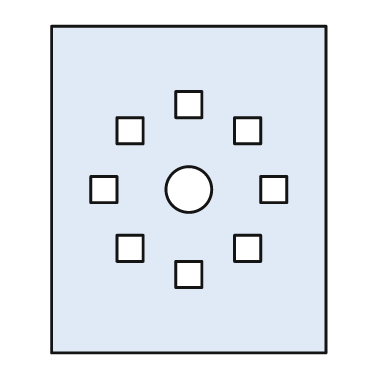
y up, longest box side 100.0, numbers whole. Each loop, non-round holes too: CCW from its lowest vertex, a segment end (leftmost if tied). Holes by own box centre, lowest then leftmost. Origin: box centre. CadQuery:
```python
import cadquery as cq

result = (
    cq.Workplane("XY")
    .moveTo(-42.0, -50.0)
    .lineTo(42.0, -50.0)
    .lineTo(42.0, 50.0)
    .lineTo(-42.0, 50.0)
    .close()
    .moveTo(-4.0, -30.0)
    .lineTo(4.0, -30.0)
    .lineTo(4.0, -22.0)
    .lineTo(-4.0, -22.0)
    .close()
    .moveTo(-22.0, -22.0)
    .lineTo(-14.0, -22.0)
    .lineTo(-14.0, -14.0)
    .lineTo(-22.0, -14.0)
    .close()
    .moveTo(14.0, -22.0)
    .lineTo(22.0, -22.0)
    .lineTo(22.0, -14.0)
    .lineTo(14.0, -14.0)
    .close()
    .moveTo(-30.0, -4.0)
    .lineTo(-22.0, -4.0)
    .lineTo(-22.0, 4.0)
    .lineTo(-30.0, 4.0)
    .close()
    .moveTo(0.0, 0.0)
    .circle(7.0)
    .moveTo(22.0, -4.0)
    .lineTo(30.0, -4.0)
    .lineTo(30.0, 4.0)
    .lineTo(22.0, 4.0)
    .close()
    .moveTo(-22.0, 14.0)
    .lineTo(-14.0, 14.0)
    .lineTo(-14.0, 22.0)
    .lineTo(-22.0, 22.0)
    .close()
    .moveTo(14.0, 14.0)
    .lineTo(22.0, 14.0)
    .lineTo(22.0, 22.0)
    .lineTo(14.0, 22.0)
    .close()
    .moveTo(-4.0, 22.0)
    .lineTo(4.0, 22.0)
    .lineTo(4.0, 30.0)
    .lineTo(-4.0, 30.0)
    .close()
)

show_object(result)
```